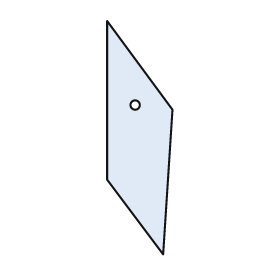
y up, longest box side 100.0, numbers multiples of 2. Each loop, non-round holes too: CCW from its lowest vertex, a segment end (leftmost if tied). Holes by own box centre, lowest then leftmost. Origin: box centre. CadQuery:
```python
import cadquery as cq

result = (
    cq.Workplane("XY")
    .moveTo(10.0, -50.0)
    .lineTo(14.0, 12.0)
    .lineTo(-14.0, 50.0)
    .lineTo(-14.0, -18.0)
    .close()
    .moveTo(-2.0, 14.0)
    .circle(2.0)
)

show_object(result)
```